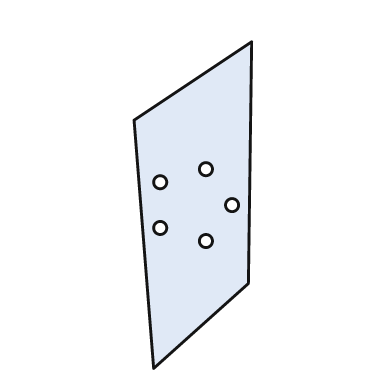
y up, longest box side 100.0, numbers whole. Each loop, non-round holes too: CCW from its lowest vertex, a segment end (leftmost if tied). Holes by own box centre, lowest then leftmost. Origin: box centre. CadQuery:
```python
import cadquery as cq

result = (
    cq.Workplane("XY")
    .moveTo(-12.0, -50.0)
    .lineTo(17.0, -24.0)
    .lineTo(18.0, 50.0)
    .lineTo(-18.0, 26.0)
    .close()
    .moveTo(4.0, -11.0)
    .circle(2.0)
    .moveTo(-10.0, -7.0)
    .circle(2.0)
    .moveTo(12.0, 0.0)
    .circle(2.0)
    .moveTo(-10.0, 7.0)
    .circle(2.0)
    .moveTo(4.0, 11.0)
    .circle(2.0)
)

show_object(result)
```